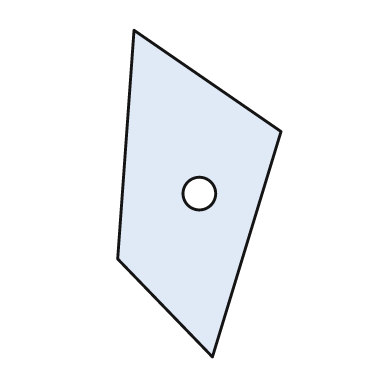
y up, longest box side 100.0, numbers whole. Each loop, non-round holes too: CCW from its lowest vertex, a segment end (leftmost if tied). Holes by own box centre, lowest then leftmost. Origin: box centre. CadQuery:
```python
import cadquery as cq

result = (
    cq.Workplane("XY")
    .moveTo(4.0, -50.0)
    .lineTo(25.0, 19.0)
    .lineTo(-20.0, 50.0)
    .lineTo(-25.0, -20.0)
    .close()
    .moveTo(0.0, 0.0)
    .circle(5.0)
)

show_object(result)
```